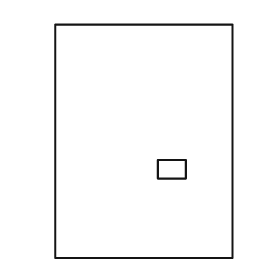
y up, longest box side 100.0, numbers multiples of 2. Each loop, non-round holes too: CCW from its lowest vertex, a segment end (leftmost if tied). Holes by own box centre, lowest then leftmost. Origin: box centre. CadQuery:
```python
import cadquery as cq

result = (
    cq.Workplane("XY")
    .moveTo(-38.0, -50.0)
    .lineTo(38.0, -50.0)
    .lineTo(38.0, 50.0)
    .lineTo(-38.0, 50.0)
    .close()
    .moveTo(6.0, -16.0)
    .lineTo(18.0, -16.0)
    .lineTo(18.0, -8.0)
    .lineTo(6.0, -8.0)
    .close()
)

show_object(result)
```